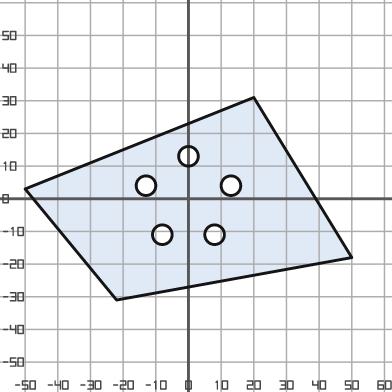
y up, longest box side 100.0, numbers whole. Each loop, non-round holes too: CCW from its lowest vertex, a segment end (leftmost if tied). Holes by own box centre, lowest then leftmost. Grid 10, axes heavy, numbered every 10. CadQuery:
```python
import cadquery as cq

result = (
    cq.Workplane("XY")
    .moveTo(-22.0, -31.0)
    .lineTo(50.0, -18.0)
    .lineTo(20.0, 31.0)
    .lineTo(-50.0, 3.0)
    .close()
    .moveTo(-8.0, -11.0)
    .circle(3.0)
    .moveTo(8.0, -11.0)
    .circle(3.0)
    .moveTo(-13.0, 4.0)
    .circle(3.0)
    .moveTo(13.0, 4.0)
    .circle(3.0)
    .moveTo(0.0, 13.0)
    .circle(3.0)
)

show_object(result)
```